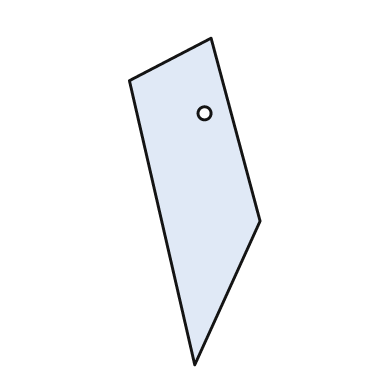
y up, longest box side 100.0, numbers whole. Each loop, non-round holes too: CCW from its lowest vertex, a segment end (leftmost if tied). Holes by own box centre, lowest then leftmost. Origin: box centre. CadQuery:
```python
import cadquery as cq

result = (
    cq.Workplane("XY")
    .moveTo(0.0, -50.0)
    .lineTo(20.0, -6.0)
    .lineTo(5.0, 50.0)
    .lineTo(-20.0, 37.0)
    .close()
    .moveTo(3.0, 27.0)
    .circle(2.0)
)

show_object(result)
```